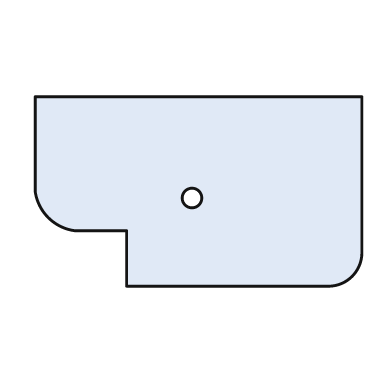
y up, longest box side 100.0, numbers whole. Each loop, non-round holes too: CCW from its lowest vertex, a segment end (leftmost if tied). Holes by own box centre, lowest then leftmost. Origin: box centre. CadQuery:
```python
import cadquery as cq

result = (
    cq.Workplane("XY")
    .moveTo(-22.0, -29.0)
    .lineTo(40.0, -29.0)
    .threePointArc((47.0, -26.0), (50.0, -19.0))
    .lineTo(50.0, 29.0)
    .lineTo(-50.0, 29.0)
    .lineTo(-50.0, 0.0)
    .threePointArc((-46.0, -8.0), (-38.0, -12.0))
    .lineTo(-22.0, -12.0)
    .close()
    .moveTo(-2.0, -2.0)
    .circle(3.0)
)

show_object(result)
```